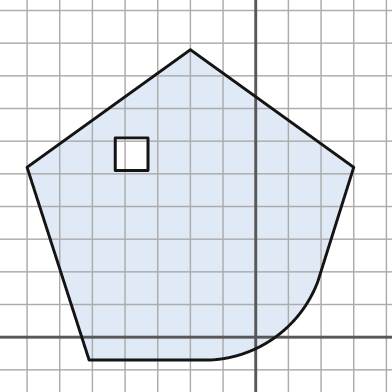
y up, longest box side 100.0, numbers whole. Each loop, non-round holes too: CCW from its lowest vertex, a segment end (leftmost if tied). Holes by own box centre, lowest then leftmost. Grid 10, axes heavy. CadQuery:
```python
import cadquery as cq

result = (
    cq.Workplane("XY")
    .moveTo(-51.0, -7.0)
    .lineTo(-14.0, -7.0)
    .threePointArc((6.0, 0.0), (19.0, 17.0))
    .lineTo(30.0, 52.0)
    .lineTo(-20.0, 88.0)
    .lineTo(-70.0, 52.0)
    .close()
    .moveTo(-43.0, 51.0)
    .lineTo(-33.0, 51.0)
    .lineTo(-33.0, 61.0)
    .lineTo(-43.0, 61.0)
    .close()
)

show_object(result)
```